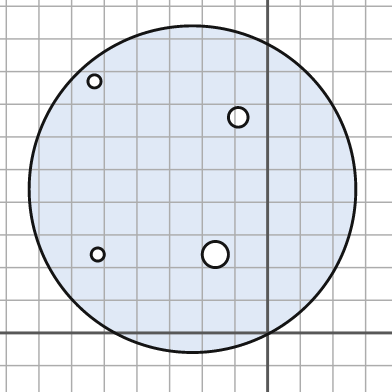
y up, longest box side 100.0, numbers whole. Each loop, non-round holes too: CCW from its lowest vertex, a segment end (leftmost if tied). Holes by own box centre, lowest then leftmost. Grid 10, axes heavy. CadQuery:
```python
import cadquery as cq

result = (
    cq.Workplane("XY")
    .moveTo(-23.0, 44.0)
    .circle(50.0)
    .moveTo(-52.0, 24.0)
    .circle(2.0)
    .moveTo(-16.0, 24.0)
    .circle(4.0)
    .moveTo(-9.0, 66.0)
    .circle(3.0)
    .moveTo(-53.0, 77.0)
    .circle(2.0)
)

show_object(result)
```